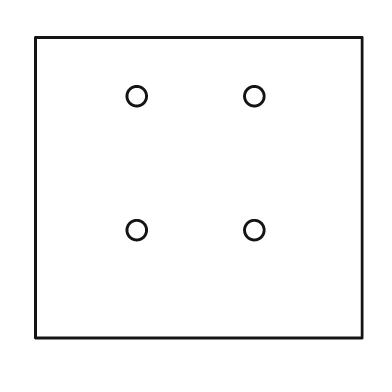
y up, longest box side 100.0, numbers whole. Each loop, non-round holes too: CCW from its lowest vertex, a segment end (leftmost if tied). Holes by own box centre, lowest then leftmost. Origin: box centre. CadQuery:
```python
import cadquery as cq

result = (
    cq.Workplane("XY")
    .moveTo(-50.0, -46.0)
    .lineTo(50.0, -46.0)
    .lineTo(50.0, 46.0)
    .lineTo(-50.0, 46.0)
    .close()
    .moveTo(-19.0, -13.0)
    .circle(3.0)
    .moveTo(17.0, -13.0)
    .circle(3.0)
    .moveTo(-19.0, 28.0)
    .circle(3.0)
    .moveTo(17.0, 28.0)
    .circle(3.0)
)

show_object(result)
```